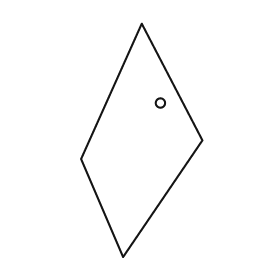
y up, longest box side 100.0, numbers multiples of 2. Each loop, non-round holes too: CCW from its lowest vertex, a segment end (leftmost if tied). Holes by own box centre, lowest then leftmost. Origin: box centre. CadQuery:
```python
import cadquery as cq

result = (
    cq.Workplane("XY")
    .moveTo(-8.0, -50.0)
    .lineTo(26.0, 0.0)
    .lineTo(0.0, 50.0)
    .lineTo(-26.0, -8.0)
    .close()
    .moveTo(8.0, 16.0)
    .circle(2.0)
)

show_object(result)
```